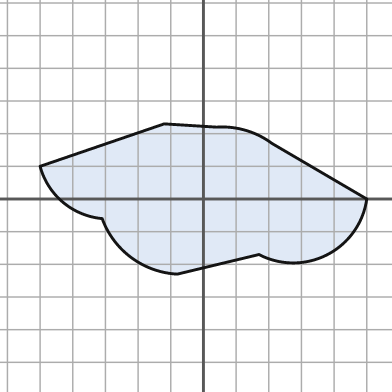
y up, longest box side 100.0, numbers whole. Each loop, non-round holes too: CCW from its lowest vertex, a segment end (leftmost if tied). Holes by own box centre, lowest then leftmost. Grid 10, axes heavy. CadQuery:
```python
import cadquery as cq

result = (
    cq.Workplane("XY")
    .moveTo(-8.0, -23.0)
    .lineTo(17.0, -17.0)
    .threePointArc((38.0, -17.0), (50.0, 0.0))
    .lineTo(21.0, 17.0)
    .threePointArc((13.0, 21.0), (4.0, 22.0))
    .lineTo(-12.0, 23.0)
    .lineTo(-50.0, 10.0)
    .threePointArc((-43.0, -1.0), (-31.0, -6.0))
    .threePointArc((-22.0, -18.0), (-8.0, -23.0))
    .close()
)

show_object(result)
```